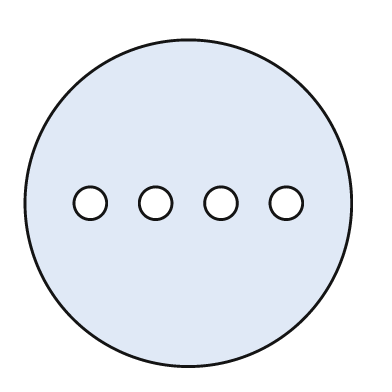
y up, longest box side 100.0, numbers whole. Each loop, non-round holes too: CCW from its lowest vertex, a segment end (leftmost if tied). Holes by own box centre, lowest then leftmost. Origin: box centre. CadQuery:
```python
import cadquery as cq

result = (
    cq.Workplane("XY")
    .moveTo(0.0, 0.0)
    .circle(50.0)
    .moveTo(-30.0, 0.0)
    .circle(5.0)
    .moveTo(-10.0, 0.0)
    .circle(5.0)
    .moveTo(10.0, 0.0)
    .circle(5.0)
    .moveTo(30.0, 0.0)
    .circle(5.0)
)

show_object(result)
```